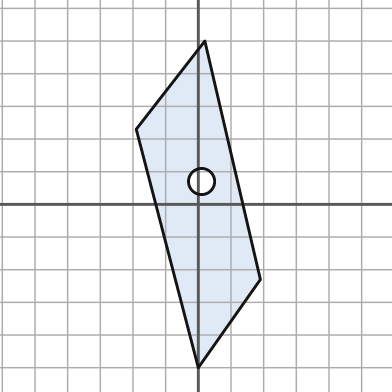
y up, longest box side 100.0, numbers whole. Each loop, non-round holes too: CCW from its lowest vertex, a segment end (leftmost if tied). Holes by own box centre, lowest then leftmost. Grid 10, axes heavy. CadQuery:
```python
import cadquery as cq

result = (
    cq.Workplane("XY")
    .moveTo(0.0, -50.0)
    .lineTo(19.0, -23.0)
    .lineTo(2.0, 50.0)
    .lineTo(-19.0, 23.0)
    .close()
    .moveTo(1.0, 7.0)
    .circle(4.0)
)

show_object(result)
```